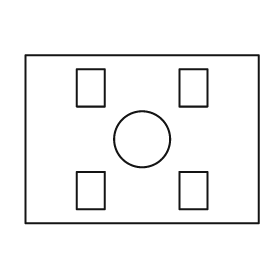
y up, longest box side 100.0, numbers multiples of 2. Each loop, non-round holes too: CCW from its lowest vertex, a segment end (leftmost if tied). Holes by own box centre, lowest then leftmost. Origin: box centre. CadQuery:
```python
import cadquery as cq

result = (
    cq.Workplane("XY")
    .moveTo(-50.0, -36.0)
    .lineTo(50.0, -36.0)
    .lineTo(50.0, 36.0)
    .lineTo(-50.0, 36.0)
    .close()
    .moveTo(-28.0, -30.0)
    .lineTo(-16.0, -30.0)
    .lineTo(-16.0, -14.0)
    .lineTo(-28.0, -14.0)
    .close()
    .moveTo(16.0, -30.0)
    .lineTo(28.0, -30.0)
    .lineTo(28.0, -14.0)
    .lineTo(16.0, -14.0)
    .close()
    .moveTo(0.0, 0.0)
    .circle(12.0)
    .moveTo(-28.0, 14.0)
    .lineTo(-16.0, 14.0)
    .lineTo(-16.0, 30.0)
    .lineTo(-28.0, 30.0)
    .close()
    .moveTo(16.0, 14.0)
    .lineTo(28.0, 14.0)
    .lineTo(28.0, 30.0)
    .lineTo(16.0, 30.0)
    .close()
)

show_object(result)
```